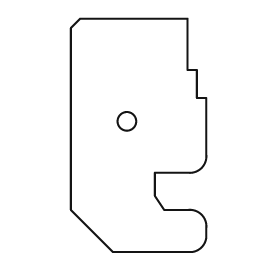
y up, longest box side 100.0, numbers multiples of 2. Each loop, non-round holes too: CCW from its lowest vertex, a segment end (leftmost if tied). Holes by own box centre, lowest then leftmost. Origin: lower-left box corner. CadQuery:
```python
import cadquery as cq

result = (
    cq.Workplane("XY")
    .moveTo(18.0, 0.0)
    .lineTo(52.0, 0.0)
    .threePointArc((56.0, 2.0), (58.0, 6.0))
    .lineTo(58.0, 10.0)
    .threePointArc((56.0, 16.0), (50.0, 18.0))
    .lineTo(40.0, 18.0)
    .lineTo(36.0, 24.0)
    .lineTo(36.0, 34.0)
    .lineTo(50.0, 34.0)
    .threePointArc((56.0, 36.0), (58.0, 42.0))
    .lineTo(58.0, 66.0)
    .lineTo(54.0, 66.0)
    .lineTo(54.0, 78.0)
    .lineTo(50.0, 78.0)
    .lineTo(50.0, 100.0)
    .lineTo(4.0, 100.0)
    .lineTo(0.0, 96.0)
    .lineTo(0.0, 18.0)
    .close()
    .moveTo(24.0, 56.0)
    .circle(4.0)
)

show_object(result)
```